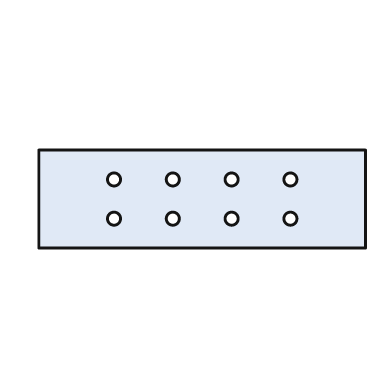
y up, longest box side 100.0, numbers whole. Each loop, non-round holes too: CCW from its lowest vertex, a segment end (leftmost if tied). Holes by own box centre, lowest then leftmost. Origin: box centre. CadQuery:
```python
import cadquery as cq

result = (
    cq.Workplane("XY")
    .moveTo(-50.0, -15.0)
    .lineTo(50.0, -15.0)
    .lineTo(50.0, 15.0)
    .lineTo(-50.0, 15.0)
    .close()
    .moveTo(-27.0, -6.0)
    .circle(2.0)
    .moveTo(-9.0, -6.0)
    .circle(2.0)
    .moveTo(9.0, -6.0)
    .circle(2.0)
    .moveTo(27.0, -6.0)
    .circle(2.0)
    .moveTo(-27.0, 6.0)
    .circle(2.0)
    .moveTo(-9.0, 6.0)
    .circle(2.0)
    .moveTo(9.0, 6.0)
    .circle(2.0)
    .moveTo(27.0, 6.0)
    .circle(2.0)
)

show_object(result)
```